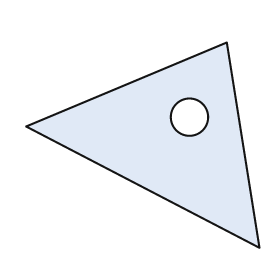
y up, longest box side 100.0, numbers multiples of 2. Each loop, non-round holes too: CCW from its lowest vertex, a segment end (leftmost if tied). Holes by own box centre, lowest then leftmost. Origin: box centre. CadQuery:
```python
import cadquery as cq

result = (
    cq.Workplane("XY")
    .moveTo(50.0, -44.0)
    .lineTo(36.0, 44.0)
    .lineTo(-50.0, 8.0)
    .close()
    .moveTo(20.0, 12.0)
    .circle(8.0)
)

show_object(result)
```